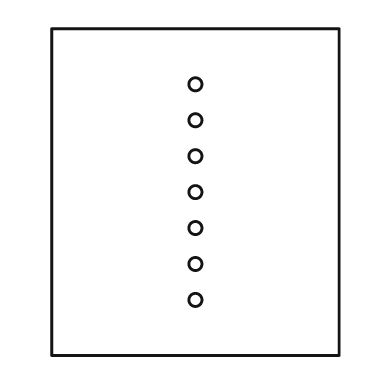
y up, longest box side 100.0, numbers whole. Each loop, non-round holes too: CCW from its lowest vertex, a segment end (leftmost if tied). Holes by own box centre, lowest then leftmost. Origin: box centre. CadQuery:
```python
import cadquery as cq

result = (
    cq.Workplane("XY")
    .moveTo(-44.0, -50.0)
    .lineTo(44.0, -50.0)
    .lineTo(44.0, 50.0)
    .lineTo(-44.0, 50.0)
    .close()
    .moveTo(0.0, -33.0)
    .circle(2.0)
    .moveTo(0.0, -22.0)
    .circle(2.0)
    .moveTo(0.0, -11.0)
    .circle(2.0)
    .moveTo(0.0, 0.0)
    .circle(2.0)
    .moveTo(0.0, 11.0)
    .circle(2.0)
    .moveTo(0.0, 22.0)
    .circle(2.0)
    .moveTo(0.0, 33.0)
    .circle(2.0)
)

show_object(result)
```